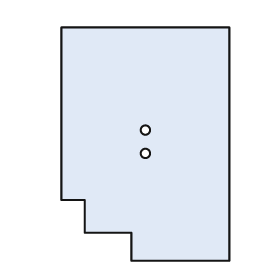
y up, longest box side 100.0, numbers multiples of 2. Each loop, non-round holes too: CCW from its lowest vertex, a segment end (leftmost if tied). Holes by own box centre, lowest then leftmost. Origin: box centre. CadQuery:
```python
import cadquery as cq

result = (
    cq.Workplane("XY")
    .moveTo(-6.0, -50.0)
    .lineTo(36.0, -50.0)
    .lineTo(36.0, 50.0)
    .lineTo(-36.0, 50.0)
    .lineTo(-36.0, -24.0)
    .lineTo(-26.0, -24.0)
    .lineTo(-26.0, -38.0)
    .lineTo(-6.0, -38.0)
    .close()
    .moveTo(0.0, -4.0)
    .circle(2.0)
    .moveTo(0.0, 6.0)
    .circle(2.0)
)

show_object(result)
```